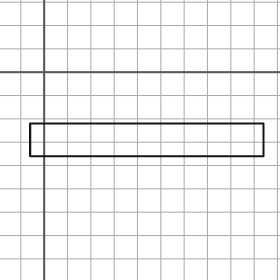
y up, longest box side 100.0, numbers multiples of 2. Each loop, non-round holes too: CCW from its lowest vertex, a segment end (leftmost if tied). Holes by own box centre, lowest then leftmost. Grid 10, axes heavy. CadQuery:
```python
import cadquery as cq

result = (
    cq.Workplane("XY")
    .moveTo(-6.0, -36.0)
    .lineTo(94.0, -36.0)
    .lineTo(94.0, -22.0)
    .lineTo(-6.0, -22.0)
    .close()
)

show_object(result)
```